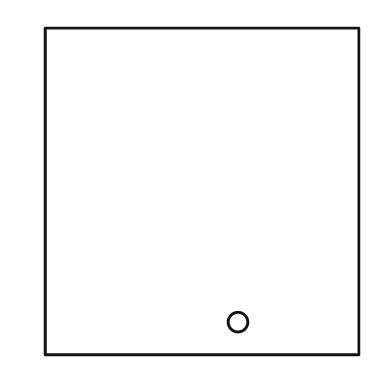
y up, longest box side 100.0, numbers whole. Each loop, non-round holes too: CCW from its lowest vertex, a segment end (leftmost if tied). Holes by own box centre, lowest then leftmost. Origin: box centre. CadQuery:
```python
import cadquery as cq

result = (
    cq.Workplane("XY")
    .moveTo(-48.0, -50.0)
    .lineTo(48.0, -50.0)
    .lineTo(48.0, 50.0)
    .lineTo(-48.0, 50.0)
    .close()
    .moveTo(11.0, -40.0)
    .circle(3.0)
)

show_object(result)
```